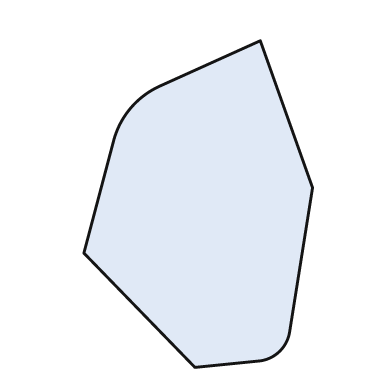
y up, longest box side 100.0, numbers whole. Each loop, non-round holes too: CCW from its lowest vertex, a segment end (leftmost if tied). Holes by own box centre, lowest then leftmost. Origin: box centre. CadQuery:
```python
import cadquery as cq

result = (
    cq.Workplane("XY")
    .moveTo(-1.0, -50.0)
    .lineTo(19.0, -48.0)
    .threePointArc((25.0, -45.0), (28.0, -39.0))
    .lineTo(35.0, 5.0)
    .lineTo(19.0, 50.0)
    .lineTo(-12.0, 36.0)
    .threePointArc((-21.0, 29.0), (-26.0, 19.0))
    .lineTo(-35.0, -15.0)
    .close()
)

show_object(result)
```